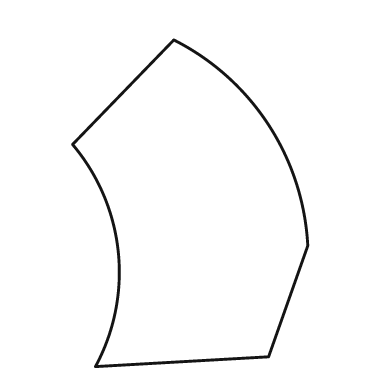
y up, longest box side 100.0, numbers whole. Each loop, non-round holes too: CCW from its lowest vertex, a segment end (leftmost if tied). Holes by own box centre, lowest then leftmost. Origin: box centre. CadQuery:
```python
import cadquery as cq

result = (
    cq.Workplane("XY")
    .moveTo(-29.0, -50.0)
    .lineTo(24.0, -47.0)
    .lineTo(36.0, -13.0)
    .threePointArc((24.0, 24.0), (-5.0, 50.0))
    .lineTo(-36.0, 18.0)
    .threePointArc((-22.0, -15.0), (-29.0, -50.0))
    .close()
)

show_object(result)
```